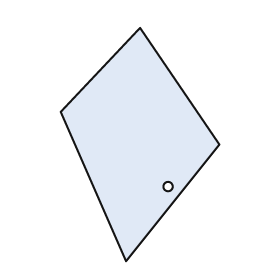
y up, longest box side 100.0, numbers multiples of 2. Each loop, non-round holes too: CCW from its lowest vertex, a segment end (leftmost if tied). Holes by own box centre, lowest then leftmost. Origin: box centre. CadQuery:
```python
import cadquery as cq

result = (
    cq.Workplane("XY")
    .moveTo(-6.0, -50.0)
    .lineTo(34.0, 0.0)
    .lineTo(0.0, 50.0)
    .lineTo(-34.0, 14.0)
    .close()
    .moveTo(12.0, -18.0)
    .circle(2.0)
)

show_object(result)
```